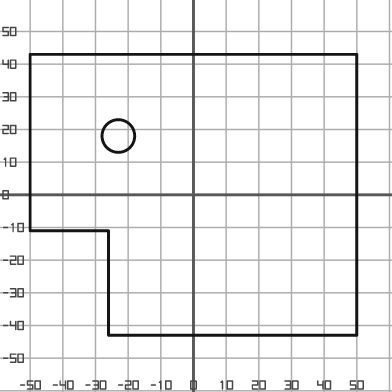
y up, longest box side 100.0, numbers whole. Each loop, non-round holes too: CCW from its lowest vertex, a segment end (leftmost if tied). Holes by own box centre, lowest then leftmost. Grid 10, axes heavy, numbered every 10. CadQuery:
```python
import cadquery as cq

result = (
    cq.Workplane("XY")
    .moveTo(-26.0, -43.0)
    .lineTo(50.0, -43.0)
    .lineTo(50.0, 43.0)
    .lineTo(-50.0, 43.0)
    .lineTo(-50.0, -11.0)
    .lineTo(-26.0, -11.0)
    .close()
    .moveTo(-23.0, 18.0)
    .circle(5.0)
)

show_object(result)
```